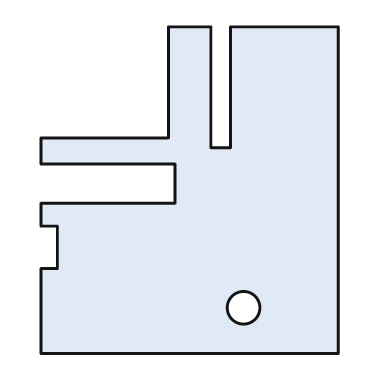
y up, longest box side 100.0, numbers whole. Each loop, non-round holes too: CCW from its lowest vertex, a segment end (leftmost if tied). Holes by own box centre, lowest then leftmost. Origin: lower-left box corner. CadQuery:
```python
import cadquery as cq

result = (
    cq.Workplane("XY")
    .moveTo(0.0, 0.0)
    .lineTo(91.0, 0.0)
    .lineTo(91.0, 100.0)
    .lineTo(58.0, 100.0)
    .lineTo(58.0, 63.0)
    .lineTo(52.0, 63.0)
    .lineTo(52.0, 100.0)
    .lineTo(39.0, 100.0)
    .lineTo(39.0, 66.0)
    .lineTo(0.0, 66.0)
    .lineTo(0.0, 58.0)
    .lineTo(41.0, 58.0)
    .lineTo(41.0, 46.0)
    .lineTo(0.0, 46.0)
    .lineTo(0.0, 39.0)
    .lineTo(5.0, 39.0)
    .lineTo(5.0, 26.0)
    .lineTo(0.0, 26.0)
    .close()
    .moveTo(62.0, 14.0)
    .circle(5.0)
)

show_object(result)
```